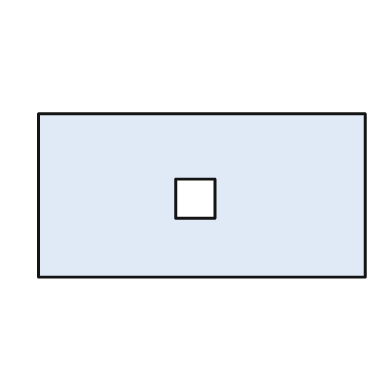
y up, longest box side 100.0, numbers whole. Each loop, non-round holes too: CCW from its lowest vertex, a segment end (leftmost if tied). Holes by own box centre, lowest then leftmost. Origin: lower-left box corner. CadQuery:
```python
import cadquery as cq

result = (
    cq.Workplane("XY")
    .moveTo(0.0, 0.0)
    .lineTo(100.0, 0.0)
    .lineTo(100.0, 50.0)
    .lineTo(0.0, 50.0)
    .close()
    .moveTo(42.0, 18.0)
    .lineTo(54.0, 18.0)
    .lineTo(54.0, 30.0)
    .lineTo(42.0, 30.0)
    .close()
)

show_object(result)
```